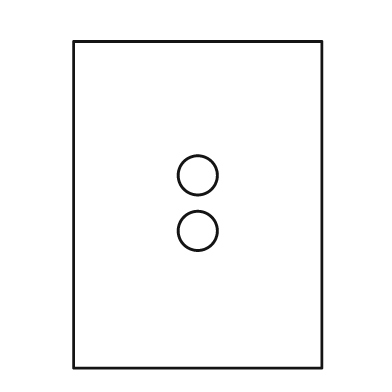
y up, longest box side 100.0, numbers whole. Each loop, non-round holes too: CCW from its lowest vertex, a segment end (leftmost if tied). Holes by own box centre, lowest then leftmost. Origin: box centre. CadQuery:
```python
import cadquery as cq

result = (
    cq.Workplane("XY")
    .moveTo(-38.0, -50.0)
    .lineTo(38.0, -50.0)
    .lineTo(38.0, 50.0)
    .lineTo(-38.0, 50.0)
    .close()
    .moveTo(0.0, -8.0)
    .circle(6.0)
    .moveTo(0.0, 9.0)
    .circle(6.0)
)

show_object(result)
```